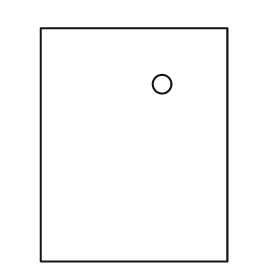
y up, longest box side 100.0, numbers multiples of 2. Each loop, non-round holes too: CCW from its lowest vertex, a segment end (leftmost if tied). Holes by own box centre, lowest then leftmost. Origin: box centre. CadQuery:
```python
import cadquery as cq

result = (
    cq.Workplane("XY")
    .moveTo(-40.0, -50.0)
    .lineTo(40.0, -50.0)
    .lineTo(40.0, 50.0)
    .lineTo(-40.0, 50.0)
    .close()
    .moveTo(12.0, 26.0)
    .circle(4.0)
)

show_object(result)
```